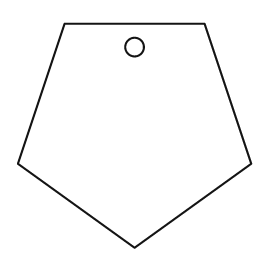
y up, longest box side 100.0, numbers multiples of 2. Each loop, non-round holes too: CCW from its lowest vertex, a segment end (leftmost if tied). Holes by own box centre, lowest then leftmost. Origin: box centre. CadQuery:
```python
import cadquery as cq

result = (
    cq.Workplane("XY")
    .moveTo(0.0, -48.0)
    .lineTo(50.0, -12.0)
    .lineTo(30.0, 48.0)
    .lineTo(-30.0, 48.0)
    .lineTo(-50.0, -12.0)
    .close()
    .moveTo(0.0, 38.0)
    .circle(4.0)
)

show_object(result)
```